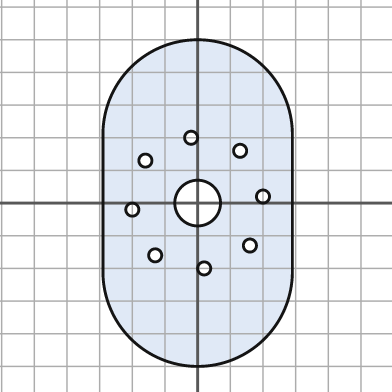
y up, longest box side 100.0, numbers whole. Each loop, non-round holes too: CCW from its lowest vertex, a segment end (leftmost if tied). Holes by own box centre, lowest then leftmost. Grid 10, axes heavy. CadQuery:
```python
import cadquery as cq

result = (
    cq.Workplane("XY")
    .moveTo(-29.0, -21.0)
    .threePointArc((0.0, -50.0), (29.0, -21.0))
    .lineTo(29.0, 21.0)
    .threePointArc((0.0, 50.0), (-29.0, 21.0))
    .close()
    .moveTo(2.0, -20.0)
    .circle(2.0)
    .moveTo(-13.0, -16.0)
    .circle(2.0)
    .moveTo(16.0, -13.0)
    .circle(2.0)
    .moveTo(-20.0, -2.0)
    .circle(2.0)
    .moveTo(0.0, 0.0)
    .circle(7.0)
    .moveTo(20.0, 2.0)
    .circle(2.0)
    .moveTo(-16.0, 13.0)
    .circle(2.0)
    .moveTo(13.0, 16.0)
    .circle(2.0)
    .moveTo(-2.0, 20.0)
    .circle(2.0)
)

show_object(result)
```